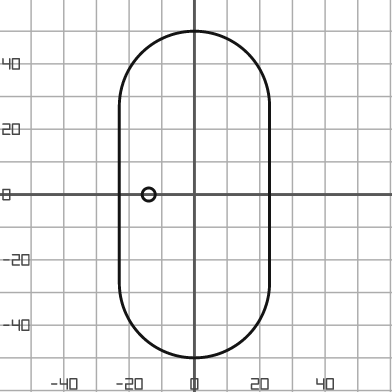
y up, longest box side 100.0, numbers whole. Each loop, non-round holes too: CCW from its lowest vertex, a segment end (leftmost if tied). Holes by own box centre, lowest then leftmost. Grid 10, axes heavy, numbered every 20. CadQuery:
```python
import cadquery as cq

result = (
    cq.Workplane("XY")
    .moveTo(-23.0, -27.0)
    .threePointArc((0.0, -50.0), (23.0, -27.0))
    .lineTo(23.0, 27.0)
    .threePointArc((0.0, 50.0), (-23.0, 27.0))
    .close()
    .moveTo(-14.0, 0.0)
    .circle(2.0)
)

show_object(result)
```